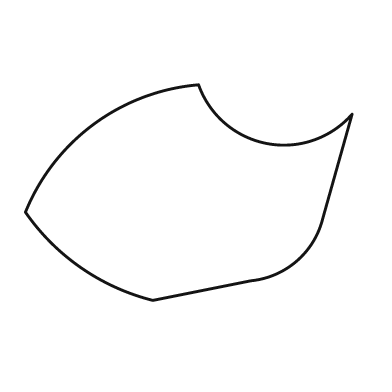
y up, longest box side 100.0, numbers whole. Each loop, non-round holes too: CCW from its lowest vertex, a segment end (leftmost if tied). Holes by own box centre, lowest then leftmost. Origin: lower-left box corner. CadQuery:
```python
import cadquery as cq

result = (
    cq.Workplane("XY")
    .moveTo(39.0, 0.0)
    .lineTo(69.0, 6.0)
    .threePointArc((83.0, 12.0), (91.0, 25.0))
    .lineTo(100.0, 57.0)
    .threePointArc((74.0, 48.0), (53.0, 66.0))
    .threePointArc((21.0, 54.0), (0.0, 27.0))
    .threePointArc((17.0, 10.0), (39.0, 0.0))
    .close()
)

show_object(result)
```